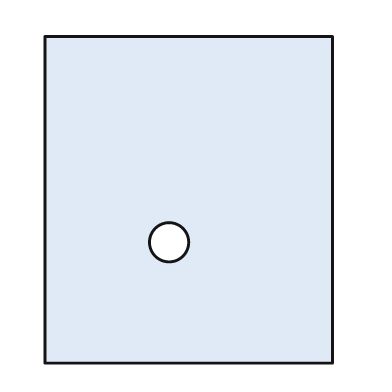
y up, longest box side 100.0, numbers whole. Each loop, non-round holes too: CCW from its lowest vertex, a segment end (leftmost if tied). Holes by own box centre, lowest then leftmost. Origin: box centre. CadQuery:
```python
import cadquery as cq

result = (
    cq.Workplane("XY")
    .moveTo(-44.0, -50.0)
    .lineTo(44.0, -50.0)
    .lineTo(44.0, 50.0)
    .lineTo(-44.0, 50.0)
    .close()
    .moveTo(-6.0, -13.0)
    .circle(6.0)
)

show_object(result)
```